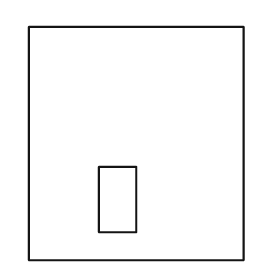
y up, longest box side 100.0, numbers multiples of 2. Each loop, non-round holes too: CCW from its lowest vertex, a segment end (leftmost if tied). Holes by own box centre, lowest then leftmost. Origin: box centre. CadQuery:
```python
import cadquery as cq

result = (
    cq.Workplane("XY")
    .moveTo(-46.0, -50.0)
    .lineTo(46.0, -50.0)
    .lineTo(46.0, 50.0)
    .lineTo(-46.0, 50.0)
    .close()
    .moveTo(-16.0, -38.0)
    .lineTo(0.0, -38.0)
    .lineTo(0.0, -10.0)
    .lineTo(-16.0, -10.0)
    .close()
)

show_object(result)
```